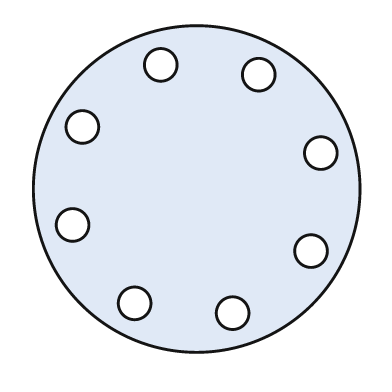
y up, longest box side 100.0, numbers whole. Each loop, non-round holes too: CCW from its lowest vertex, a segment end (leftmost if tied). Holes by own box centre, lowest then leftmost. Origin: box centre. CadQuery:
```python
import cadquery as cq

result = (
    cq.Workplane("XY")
    .moveTo(0.0, 0.0)
    .circle(50.0)
    .moveTo(11.0, -38.0)
    .circle(5.0)
    .moveTo(-19.0, -35.0)
    .circle(5.0)
    .moveTo(35.0, -19.0)
    .circle(5.0)
    .moveTo(-38.0, -11.0)
    .circle(5.0)
    .moveTo(38.0, 11.0)
    .circle(5.0)
    .moveTo(-35.0, 19.0)
    .circle(5.0)
    .moveTo(19.0, 35.0)
    .circle(5.0)
    .moveTo(-11.0, 38.0)
    .circle(5.0)
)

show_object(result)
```